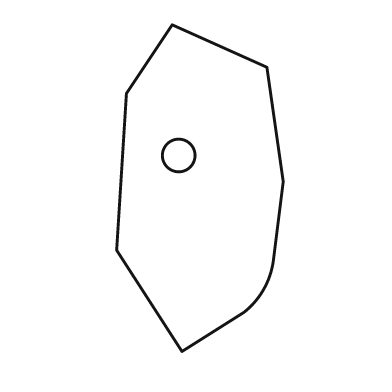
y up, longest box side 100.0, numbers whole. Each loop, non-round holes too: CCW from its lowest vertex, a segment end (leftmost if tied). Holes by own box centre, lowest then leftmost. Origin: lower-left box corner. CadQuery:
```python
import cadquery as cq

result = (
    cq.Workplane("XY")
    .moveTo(20.0, 0.0)
    .lineTo(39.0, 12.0)
    .threePointArc((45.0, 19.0), (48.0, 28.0))
    .lineTo(51.0, 52.0)
    .lineTo(46.0, 87.0)
    .lineTo(17.0, 100.0)
    .lineTo(3.0, 79.0)
    .lineTo(0.0, 31.0)
    .close()
    .moveTo(19.0, 60.0)
    .circle(5.0)
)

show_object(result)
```